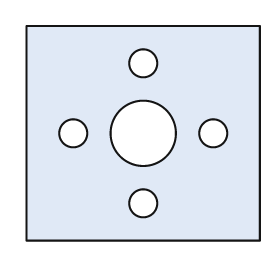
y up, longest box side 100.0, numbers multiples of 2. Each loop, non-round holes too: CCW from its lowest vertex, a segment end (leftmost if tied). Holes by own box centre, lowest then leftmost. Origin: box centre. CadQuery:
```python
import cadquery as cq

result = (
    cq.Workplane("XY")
    .moveTo(-50.0, -46.0)
    .lineTo(50.0, -46.0)
    .lineTo(50.0, 46.0)
    .lineTo(-50.0, 46.0)
    .close()
    .moveTo(0.0, -30.0)
    .circle(6.0)
    .moveTo(-30.0, 0.0)
    .circle(6.0)
    .moveTo(0.0, 0.0)
    .circle(14.0)
    .moveTo(30.0, 0.0)
    .circle(6.0)
    .moveTo(0.0, 30.0)
    .circle(6.0)
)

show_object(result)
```